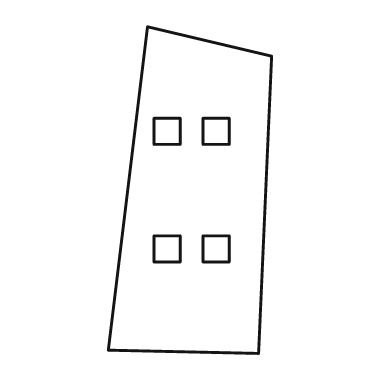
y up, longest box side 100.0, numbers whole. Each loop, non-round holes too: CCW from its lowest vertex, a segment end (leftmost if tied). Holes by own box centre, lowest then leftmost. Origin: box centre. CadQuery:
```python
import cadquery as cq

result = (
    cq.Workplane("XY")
    .moveTo(21.0, -50.0)
    .lineTo(25.0, 41.0)
    .lineTo(-13.0, 50.0)
    .lineTo(-25.0, -49.0)
    .close()
    .moveTo(-11.0, -22.0)
    .lineTo(-3.0, -22.0)
    .lineTo(-3.0, -14.0)
    .lineTo(-11.0, -14.0)
    .close()
    .moveTo(4.0, -22.0)
    .lineTo(12.0, -22.0)
    .lineTo(12.0, -14.0)
    .lineTo(4.0, -14.0)
    .close()
    .moveTo(-11.0, 14.0)
    .lineTo(-3.0, 14.0)
    .lineTo(-3.0, 22.0)
    .lineTo(-11.0, 22.0)
    .close()
    .moveTo(4.0, 14.0)
    .lineTo(12.0, 14.0)
    .lineTo(12.0, 22.0)
    .lineTo(4.0, 22.0)
    .close()
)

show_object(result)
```